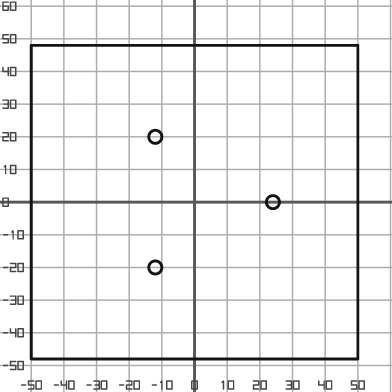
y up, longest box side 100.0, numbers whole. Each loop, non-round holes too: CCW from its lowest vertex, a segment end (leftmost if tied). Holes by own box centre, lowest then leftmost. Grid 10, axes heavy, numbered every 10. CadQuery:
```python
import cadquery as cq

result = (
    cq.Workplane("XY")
    .moveTo(-50.0, -48.0)
    .lineTo(50.0, -48.0)
    .lineTo(50.0, 48.0)
    .lineTo(-50.0, 48.0)
    .close()
    .moveTo(-12.0, -20.0)
    .circle(2.0)
    .moveTo(24.0, 0.0)
    .circle(2.0)
    .moveTo(-12.0, 20.0)
    .circle(2.0)
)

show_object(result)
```